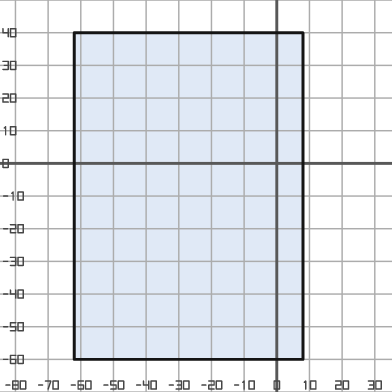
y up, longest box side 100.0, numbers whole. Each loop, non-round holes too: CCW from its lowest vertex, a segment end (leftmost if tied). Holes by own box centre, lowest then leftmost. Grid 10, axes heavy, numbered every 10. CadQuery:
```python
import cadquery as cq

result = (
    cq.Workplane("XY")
    .moveTo(-62.0, -60.0)
    .lineTo(8.0, -60.0)
    .lineTo(8.0, 40.0)
    .lineTo(-62.0, 40.0)
    .close()
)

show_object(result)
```